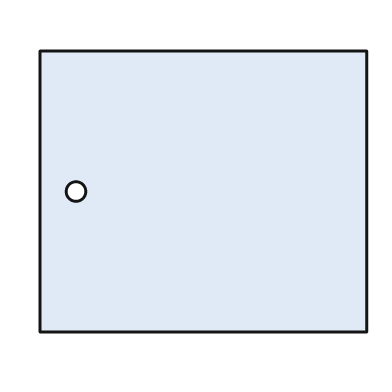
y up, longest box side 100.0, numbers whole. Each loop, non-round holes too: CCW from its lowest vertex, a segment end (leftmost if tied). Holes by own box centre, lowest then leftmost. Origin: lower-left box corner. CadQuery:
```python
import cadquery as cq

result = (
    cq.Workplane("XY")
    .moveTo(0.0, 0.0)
    .lineTo(100.0, 0.0)
    .lineTo(100.0, 86.0)
    .lineTo(0.0, 86.0)
    .close()
    .moveTo(11.0, 43.0)
    .circle(3.0)
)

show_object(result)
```